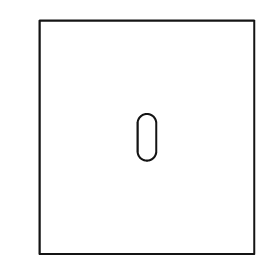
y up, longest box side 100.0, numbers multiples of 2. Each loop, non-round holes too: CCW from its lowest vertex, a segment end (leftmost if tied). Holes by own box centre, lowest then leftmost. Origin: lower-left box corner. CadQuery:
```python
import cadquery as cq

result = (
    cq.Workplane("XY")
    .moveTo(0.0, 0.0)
    .lineTo(92.0, 0.0)
    .lineTo(92.0, 100.0)
    .lineTo(0.0, 100.0)
    .close()
    .moveTo(42.0, 44.0)
    .threePointArc((46.0, 40.0), (50.0, 44.0))
    .lineTo(50.0, 56.0)
    .threePointArc((46.0, 60.0), (42.0, 56.0))
    .close()
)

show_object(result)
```